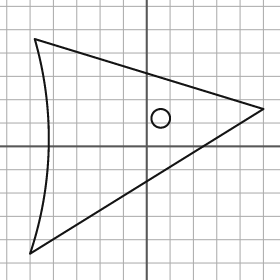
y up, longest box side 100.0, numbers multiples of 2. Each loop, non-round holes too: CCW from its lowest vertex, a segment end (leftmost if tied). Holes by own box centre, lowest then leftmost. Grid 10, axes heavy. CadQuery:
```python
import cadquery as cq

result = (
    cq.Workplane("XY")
    .moveTo(-50.0, -46.0)
    .lineTo(50.0, 16.0)
    .lineTo(-48.0, 46.0)
    .threePointArc((-42.0, 0.0), (-50.0, -46.0))
    .close()
    .moveTo(6.0, 12.0)
    .circle(4.0)
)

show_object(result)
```